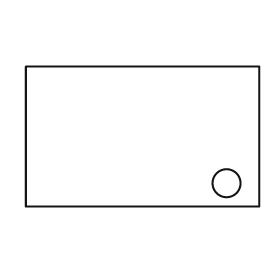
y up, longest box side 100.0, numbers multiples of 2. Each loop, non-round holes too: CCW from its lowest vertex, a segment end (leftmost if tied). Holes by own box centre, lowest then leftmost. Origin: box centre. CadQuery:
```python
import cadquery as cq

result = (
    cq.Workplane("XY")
    .moveTo(-50.0, -30.0)
    .lineTo(50.0, -30.0)
    .lineTo(50.0, 30.0)
    .lineTo(-50.0, 30.0)
    .close()
    .moveTo(36.0, -20.0)
    .circle(6.0)
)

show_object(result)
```